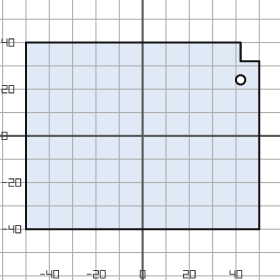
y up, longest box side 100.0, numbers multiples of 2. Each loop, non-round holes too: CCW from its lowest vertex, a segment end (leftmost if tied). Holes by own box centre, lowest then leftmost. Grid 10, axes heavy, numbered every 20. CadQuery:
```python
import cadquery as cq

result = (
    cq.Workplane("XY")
    .moveTo(-50.0, -40.0)
    .lineTo(50.0, -40.0)
    .lineTo(50.0, 32.0)
    .lineTo(42.0, 32.0)
    .lineTo(42.0, 40.0)
    .lineTo(-50.0, 40.0)
    .close()
    .moveTo(42.0, 24.0)
    .circle(2.0)
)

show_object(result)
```